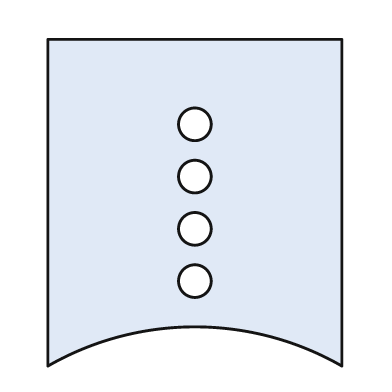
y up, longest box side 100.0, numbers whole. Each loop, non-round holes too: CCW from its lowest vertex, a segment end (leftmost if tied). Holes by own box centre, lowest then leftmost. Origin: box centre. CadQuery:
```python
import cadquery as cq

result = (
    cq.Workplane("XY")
    .moveTo(-45.0, -50.0)
    .threePointArc((0.0, -38.0), (45.0, -50.0))
    .lineTo(45.0, 50.0)
    .lineTo(-45.0, 50.0)
    .close()
    .moveTo(0.0, -24.0)
    .circle(5.0)
    .moveTo(0.0, -8.0)
    .circle(5.0)
    .moveTo(0.0, 8.0)
    .circle(5.0)
    .moveTo(0.0, 24.0)
    .circle(5.0)
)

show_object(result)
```